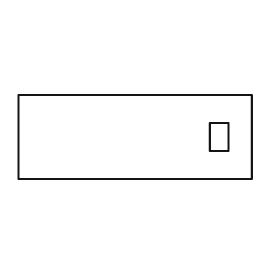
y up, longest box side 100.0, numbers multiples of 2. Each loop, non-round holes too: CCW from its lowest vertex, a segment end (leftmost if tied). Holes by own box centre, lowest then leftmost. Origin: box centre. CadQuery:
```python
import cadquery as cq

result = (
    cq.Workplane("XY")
    .moveTo(-50.0, -18.0)
    .lineTo(50.0, -18.0)
    .lineTo(50.0, 18.0)
    .lineTo(-50.0, 18.0)
    .close()
    .moveTo(32.0, -6.0)
    .lineTo(40.0, -6.0)
    .lineTo(40.0, 6.0)
    .lineTo(32.0, 6.0)
    .close()
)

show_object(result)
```